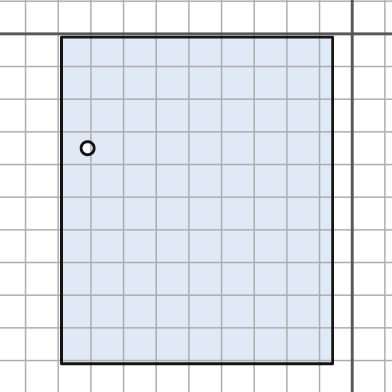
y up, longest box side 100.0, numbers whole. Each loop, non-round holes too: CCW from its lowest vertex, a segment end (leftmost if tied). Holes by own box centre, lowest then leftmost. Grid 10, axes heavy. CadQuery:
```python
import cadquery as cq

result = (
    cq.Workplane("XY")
    .moveTo(-89.0, -101.0)
    .lineTo(-6.0, -101.0)
    .lineTo(-6.0, -1.0)
    .lineTo(-89.0, -1.0)
    .close()
    .moveTo(-81.0, -35.0)
    .circle(2.0)
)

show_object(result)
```